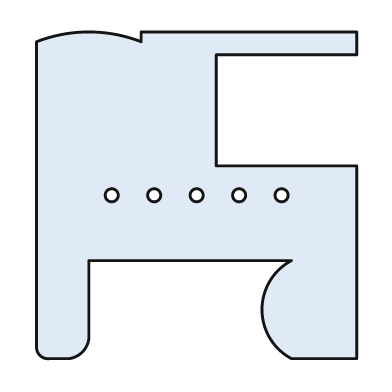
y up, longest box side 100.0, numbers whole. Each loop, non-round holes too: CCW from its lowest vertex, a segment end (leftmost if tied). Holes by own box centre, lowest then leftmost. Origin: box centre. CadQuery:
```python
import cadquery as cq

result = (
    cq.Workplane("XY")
    .moveTo(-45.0, -50.0)
    .lineTo(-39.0, -50.0)
    .threePointArc((-35.0, -48.0), (-33.0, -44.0))
    .lineTo(-33.0, -20.0)
    .lineTo(29.0, -20.0)
    .threePointArc((20.0, -35.0), (29.0, -50.0))
    .lineTo(49.0, -50.0)
    .lineTo(49.0, 9.0)
    .lineTo(6.0, 9.0)
    .lineTo(6.0, 43.0)
    .lineTo(49.0, 43.0)
    .lineTo(49.0, 50.0)
    .lineTo(-17.0, 50.0)
    .lineTo(-17.0, 47.0)
    .threePointArc((-33.0, 50.0), (-49.0, 47.0))
    .lineTo(-49.0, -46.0)
    .threePointArc((-48.0, -49.0), (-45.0, -50.0))
    .close()
    .moveTo(-26.0, 0.0)
    .circle(2.0)
    .moveTo(-13.0, 0.0)
    .circle(2.0)
    .moveTo(0.0, 0.0)
    .circle(2.0)
    .moveTo(13.0, 0.0)
    .circle(2.0)
    .moveTo(26.0, 0.0)
    .circle(2.0)
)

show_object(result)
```